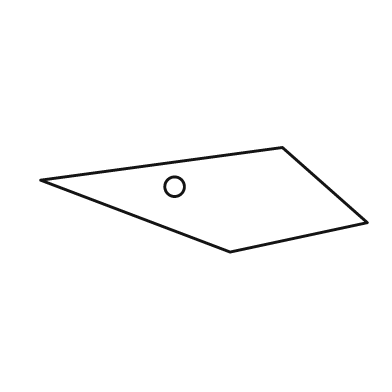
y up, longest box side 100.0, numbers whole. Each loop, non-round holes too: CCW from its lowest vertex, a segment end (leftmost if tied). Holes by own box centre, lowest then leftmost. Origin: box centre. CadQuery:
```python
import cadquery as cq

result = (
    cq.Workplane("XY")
    .moveTo(8.0, -16.0)
    .lineTo(50.0, -7.0)
    .lineTo(24.0, 16.0)
    .lineTo(-50.0, 6.0)
    .close()
    .moveTo(-9.0, 4.0)
    .circle(3.0)
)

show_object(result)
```